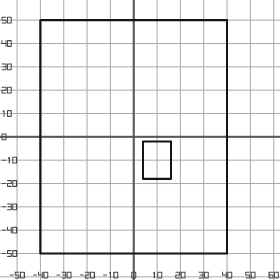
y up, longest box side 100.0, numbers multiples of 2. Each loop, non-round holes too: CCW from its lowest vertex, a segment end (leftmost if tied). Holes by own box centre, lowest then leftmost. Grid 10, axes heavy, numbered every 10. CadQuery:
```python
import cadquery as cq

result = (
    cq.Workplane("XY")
    .moveTo(-40.0, -50.0)
    .lineTo(40.0, -50.0)
    .lineTo(40.0, 50.0)
    .lineTo(-40.0, 50.0)
    .close()
    .moveTo(4.0, -18.0)
    .lineTo(16.0, -18.0)
    .lineTo(16.0, -2.0)
    .lineTo(4.0, -2.0)
    .close()
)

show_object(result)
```